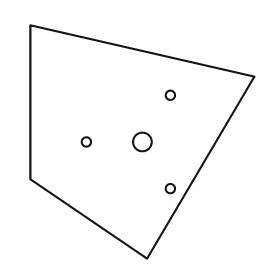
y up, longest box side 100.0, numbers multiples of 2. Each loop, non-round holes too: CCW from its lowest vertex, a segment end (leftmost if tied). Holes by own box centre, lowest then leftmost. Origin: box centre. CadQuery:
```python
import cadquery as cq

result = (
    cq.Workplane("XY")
    .moveTo(2.0, -50.0)
    .lineTo(48.0, 28.0)
    .lineTo(-48.0, 50.0)
    .lineTo(-48.0, -16.0)
    .close()
    .moveTo(12.0, -20.0)
    .circle(2.0)
    .moveTo(-24.0, 0.0)
    .circle(2.0)
    .moveTo(0.0, 0.0)
    .circle(4.0)
    .moveTo(12.0, 20.0)
    .circle(2.0)
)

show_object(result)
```